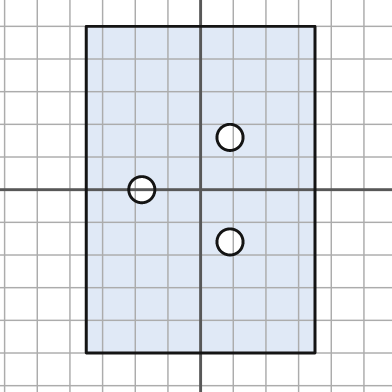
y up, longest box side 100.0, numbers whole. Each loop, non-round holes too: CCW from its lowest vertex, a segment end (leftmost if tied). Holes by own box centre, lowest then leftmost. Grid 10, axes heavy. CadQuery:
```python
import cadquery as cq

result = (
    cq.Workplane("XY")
    .moveTo(-35.0, -50.0)
    .lineTo(35.0, -50.0)
    .lineTo(35.0, 50.0)
    .lineTo(-35.0, 50.0)
    .close()
    .moveTo(9.0, -16.0)
    .circle(4.0)
    .moveTo(-18.0, 0.0)
    .circle(4.0)
    .moveTo(9.0, 16.0)
    .circle(4.0)
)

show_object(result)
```